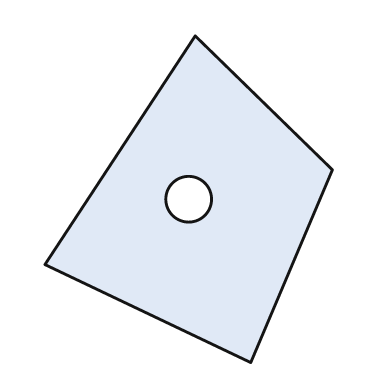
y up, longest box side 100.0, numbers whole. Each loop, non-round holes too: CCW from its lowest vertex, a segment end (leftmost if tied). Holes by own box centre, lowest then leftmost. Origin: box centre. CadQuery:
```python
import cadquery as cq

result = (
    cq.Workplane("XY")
    .moveTo(19.0, -50.0)
    .lineTo(44.0, 9.0)
    .lineTo(2.0, 50.0)
    .lineTo(-44.0, -20.0)
    .close()
    .moveTo(0.0, 0.0)
    .circle(7.0)
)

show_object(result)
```